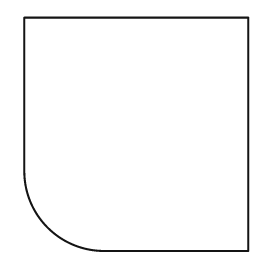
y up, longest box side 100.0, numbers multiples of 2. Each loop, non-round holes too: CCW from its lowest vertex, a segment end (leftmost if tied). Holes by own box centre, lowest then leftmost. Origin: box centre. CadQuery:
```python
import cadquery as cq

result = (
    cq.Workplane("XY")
    .moveTo(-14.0, -50.0)
    .lineTo(48.0, -50.0)
    .lineTo(48.0, 50.0)
    .lineTo(-48.0, 50.0)
    .lineTo(-48.0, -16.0)
    .threePointArc((-38.0, -40.0), (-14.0, -50.0))
    .close()
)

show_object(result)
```